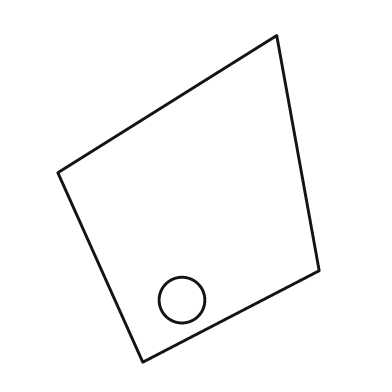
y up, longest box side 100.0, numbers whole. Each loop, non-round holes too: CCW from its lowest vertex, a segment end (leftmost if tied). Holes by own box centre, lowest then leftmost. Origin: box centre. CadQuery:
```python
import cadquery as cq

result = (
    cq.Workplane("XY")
    .moveTo(-14.0, -50.0)
    .lineTo(40.0, -22.0)
    .lineTo(27.0, 50.0)
    .lineTo(-40.0, 8.0)
    .close()
    .moveTo(-2.0, -31.0)
    .circle(7.0)
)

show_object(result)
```